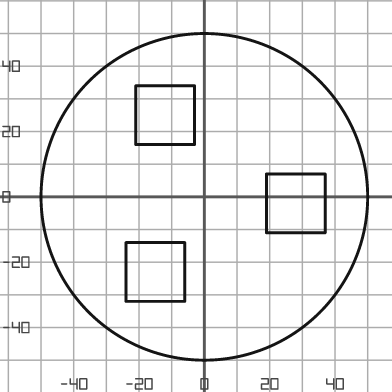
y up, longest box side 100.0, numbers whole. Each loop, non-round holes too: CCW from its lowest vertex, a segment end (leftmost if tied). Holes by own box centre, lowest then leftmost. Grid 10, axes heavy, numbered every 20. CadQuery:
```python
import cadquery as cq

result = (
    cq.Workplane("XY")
    .moveTo(0.0, 0.0)
    .circle(50.0)
    .moveTo(-24.0, -32.0)
    .lineTo(-6.0, -32.0)
    .lineTo(-6.0, -14.0)
    .lineTo(-24.0, -14.0)
    .close()
    .moveTo(19.0, -11.0)
    .lineTo(37.0, -11.0)
    .lineTo(37.0, 7.0)
    .lineTo(19.0, 7.0)
    .close()
    .moveTo(-21.0, 16.0)
    .lineTo(-3.0, 16.0)
    .lineTo(-3.0, 34.0)
    .lineTo(-21.0, 34.0)
    .close()
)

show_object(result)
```